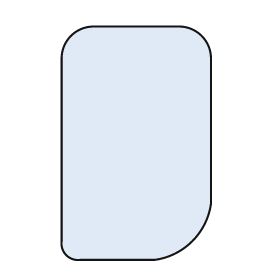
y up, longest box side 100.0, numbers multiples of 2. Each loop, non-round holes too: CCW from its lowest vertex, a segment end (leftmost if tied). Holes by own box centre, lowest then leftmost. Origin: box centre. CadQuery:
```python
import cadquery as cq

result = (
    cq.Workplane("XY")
    .moveTo(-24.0, -50.0)
    .lineTo(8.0, -50.0)
    .threePointArc((24.0, -42.0), (32.0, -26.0))
    .lineTo(32.0, 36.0)
    .threePointArc((28.0, 46.0), (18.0, 50.0))
    .lineTo(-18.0, 50.0)
    .threePointArc((-28.0, 46.0), (-32.0, 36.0))
    .lineTo(-32.0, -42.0)
    .threePointArc((-30.0, -48.0), (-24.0, -50.0))
    .close()
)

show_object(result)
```